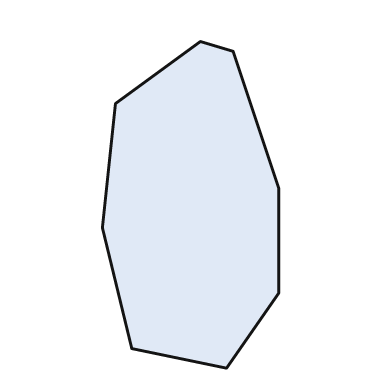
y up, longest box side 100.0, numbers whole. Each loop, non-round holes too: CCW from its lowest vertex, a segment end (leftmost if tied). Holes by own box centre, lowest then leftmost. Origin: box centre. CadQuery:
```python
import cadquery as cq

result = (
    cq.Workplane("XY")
    .moveTo(11.0, -50.0)
    .lineTo(27.0, -27.0)
    .lineTo(27.0, 5.0)
    .lineTo(13.0, 47.0)
    .lineTo(3.0, 50.0)
    .lineTo(-23.0, 31.0)
    .lineTo(-27.0, -7.0)
    .lineTo(-18.0, -44.0)
    .close()
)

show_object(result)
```